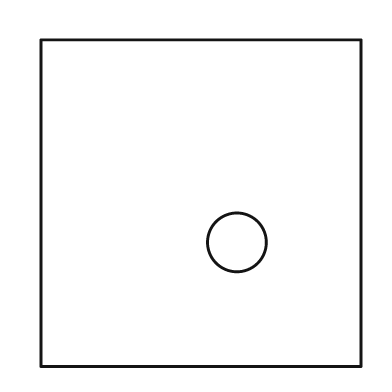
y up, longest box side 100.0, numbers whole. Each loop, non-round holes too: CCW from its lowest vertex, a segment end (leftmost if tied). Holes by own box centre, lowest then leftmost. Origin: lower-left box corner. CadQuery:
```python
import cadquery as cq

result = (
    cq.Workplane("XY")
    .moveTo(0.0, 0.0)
    .lineTo(98.0, 0.0)
    .lineTo(98.0, 100.0)
    .lineTo(0.0, 100.0)
    .close()
    .moveTo(60.0, 38.0)
    .circle(9.0)
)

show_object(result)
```